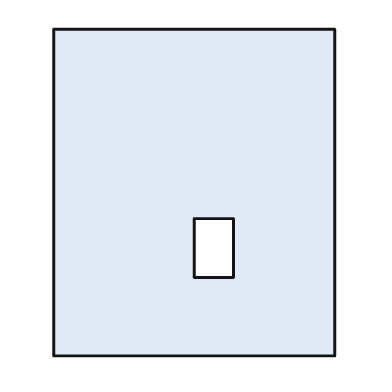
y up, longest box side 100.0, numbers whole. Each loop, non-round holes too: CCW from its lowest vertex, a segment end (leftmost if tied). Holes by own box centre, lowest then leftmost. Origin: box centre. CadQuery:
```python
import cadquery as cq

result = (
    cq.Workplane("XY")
    .moveTo(-43.0, -50.0)
    .lineTo(43.0, -50.0)
    .lineTo(43.0, 50.0)
    .lineTo(-43.0, 50.0)
    .close()
    .moveTo(0.0, -26.0)
    .lineTo(12.0, -26.0)
    .lineTo(12.0, -8.0)
    .lineTo(0.0, -8.0)
    .close()
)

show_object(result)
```